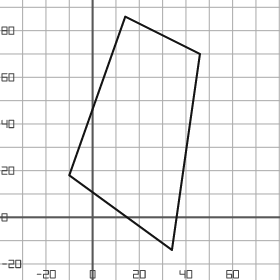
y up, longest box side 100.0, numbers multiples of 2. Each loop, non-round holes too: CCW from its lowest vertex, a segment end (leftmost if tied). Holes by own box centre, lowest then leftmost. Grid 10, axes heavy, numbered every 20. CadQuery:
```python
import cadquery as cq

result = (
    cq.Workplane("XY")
    .moveTo(34.0, -14.0)
    .lineTo(46.0, 70.0)
    .lineTo(14.0, 86.0)
    .lineTo(-10.0, 18.0)
    .close()
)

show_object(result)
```